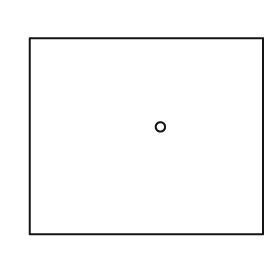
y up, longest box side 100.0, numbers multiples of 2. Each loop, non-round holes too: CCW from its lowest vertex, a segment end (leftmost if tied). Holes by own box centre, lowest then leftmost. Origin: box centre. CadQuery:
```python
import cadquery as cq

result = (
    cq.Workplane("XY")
    .moveTo(-50.0, -42.0)
    .lineTo(50.0, -42.0)
    .lineTo(50.0, 42.0)
    .lineTo(-50.0, 42.0)
    .close()
    .moveTo(6.0, 4.0)
    .circle(2.0)
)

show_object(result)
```